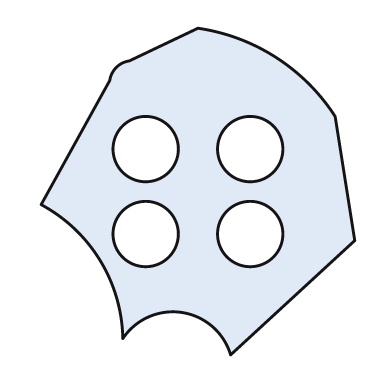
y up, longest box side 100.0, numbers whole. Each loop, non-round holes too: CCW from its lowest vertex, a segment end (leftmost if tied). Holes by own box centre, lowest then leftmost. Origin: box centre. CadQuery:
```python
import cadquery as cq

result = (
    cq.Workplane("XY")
    .moveTo(10.0, -50.0)
    .lineTo(48.0, -15.0)
    .lineTo(42.0, 23.0)
    .threePointArc((24.0, 41.0), (0.0, 50.0))
    .lineTo(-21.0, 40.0)
    .threePointArc((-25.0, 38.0), (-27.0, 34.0))
    .lineTo(-48.0, -4.0)
    .threePointArc((-30.0, -21.0), (-23.0, -45.0))
    .threePointArc((-5.0, -37.0), (10.0, -50.0))
    .close()
    .moveTo(-16.0, -13.0)
    .circle(10.0)
    .moveTo(16.0, -13.0)
    .circle(10.0)
    .moveTo(-16.0, 13.0)
    .circle(10.0)
    .moveTo(16.0, 13.0)
    .circle(10.0)
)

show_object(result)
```